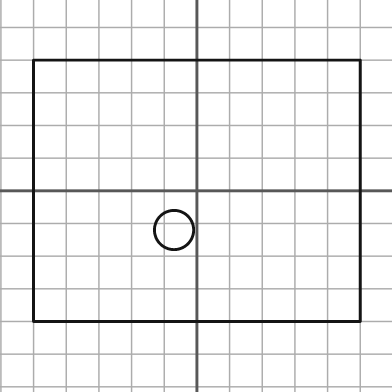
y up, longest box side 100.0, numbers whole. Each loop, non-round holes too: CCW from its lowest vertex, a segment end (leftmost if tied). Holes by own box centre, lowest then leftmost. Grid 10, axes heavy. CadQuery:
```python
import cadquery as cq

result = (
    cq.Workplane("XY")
    .moveTo(-50.0, -40.0)
    .lineTo(50.0, -40.0)
    .lineTo(50.0, 40.0)
    .lineTo(-50.0, 40.0)
    .close()
    .moveTo(-7.0, -12.0)
    .circle(6.0)
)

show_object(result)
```